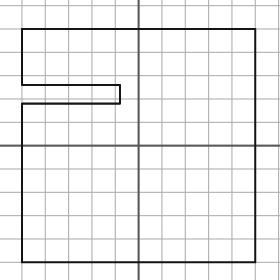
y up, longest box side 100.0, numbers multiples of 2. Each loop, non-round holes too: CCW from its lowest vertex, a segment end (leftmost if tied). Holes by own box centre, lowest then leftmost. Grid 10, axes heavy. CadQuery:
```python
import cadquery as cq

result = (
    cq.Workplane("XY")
    .moveTo(-50.0, -50.0)
    .lineTo(50.0, -50.0)
    .lineTo(50.0, 50.0)
    .lineTo(-50.0, 50.0)
    .lineTo(-50.0, 26.0)
    .lineTo(-8.0, 26.0)
    .lineTo(-8.0, 18.0)
    .lineTo(-50.0, 18.0)
    .close()
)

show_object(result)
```